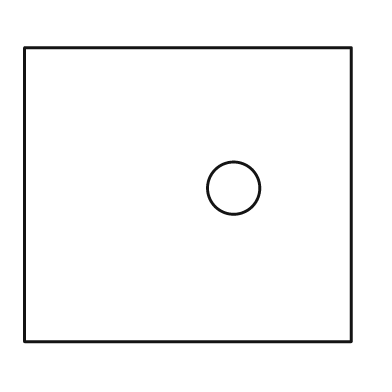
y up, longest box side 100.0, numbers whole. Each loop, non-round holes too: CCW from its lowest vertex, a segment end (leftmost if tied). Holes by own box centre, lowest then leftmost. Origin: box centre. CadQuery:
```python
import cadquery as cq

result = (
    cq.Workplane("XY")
    .moveTo(-50.0, -45.0)
    .lineTo(50.0, -45.0)
    .lineTo(50.0, 45.0)
    .lineTo(-50.0, 45.0)
    .close()
    .moveTo(14.0, 2.0)
    .circle(8.0)
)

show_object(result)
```